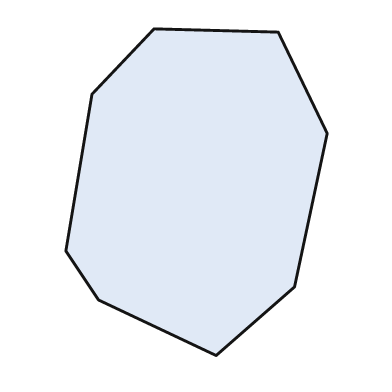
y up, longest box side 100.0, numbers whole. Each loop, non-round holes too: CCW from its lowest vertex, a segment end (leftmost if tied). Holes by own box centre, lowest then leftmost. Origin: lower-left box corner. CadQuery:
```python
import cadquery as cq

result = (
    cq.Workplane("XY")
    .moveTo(46.0, 0.0)
    .lineTo(70.0, 21.0)
    .lineTo(80.0, 68.0)
    .lineTo(65.0, 99.0)
    .lineTo(27.0, 100.0)
    .lineTo(8.0, 80.0)
    .lineTo(0.0, 32.0)
    .lineTo(10.0, 17.0)
    .close()
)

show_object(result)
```